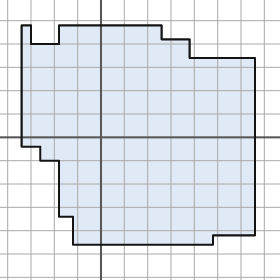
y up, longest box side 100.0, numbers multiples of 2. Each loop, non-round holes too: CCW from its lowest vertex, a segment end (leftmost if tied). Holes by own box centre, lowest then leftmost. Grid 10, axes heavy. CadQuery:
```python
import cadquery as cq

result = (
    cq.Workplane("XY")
    .moveTo(-12.0, -46.0)
    .lineTo(48.0, -46.0)
    .lineTo(48.0, -42.0)
    .lineTo(66.0, -42.0)
    .lineTo(66.0, 34.0)
    .lineTo(38.0, 34.0)
    .lineTo(38.0, 42.0)
    .lineTo(26.0, 42.0)
    .lineTo(26.0, 48.0)
    .lineTo(-18.0, 48.0)
    .lineTo(-18.0, 40.0)
    .lineTo(-30.0, 40.0)
    .lineTo(-30.0, 48.0)
    .lineTo(-34.0, 48.0)
    .lineTo(-34.0, -4.0)
    .lineTo(-26.0, -4.0)
    .lineTo(-26.0, -10.0)
    .lineTo(-18.0, -10.0)
    .lineTo(-18.0, -34.0)
    .lineTo(-12.0, -34.0)
    .close()
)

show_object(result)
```